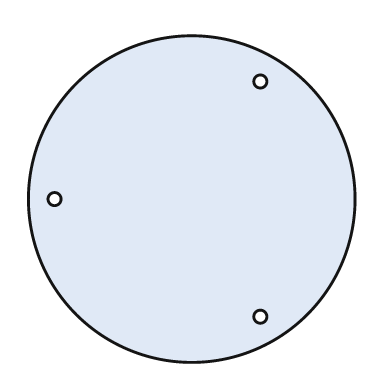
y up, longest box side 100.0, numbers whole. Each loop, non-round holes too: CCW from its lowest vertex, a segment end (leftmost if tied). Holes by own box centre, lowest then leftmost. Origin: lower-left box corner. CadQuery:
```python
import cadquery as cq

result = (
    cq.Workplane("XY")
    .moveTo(50.0, 50.0)
    .circle(50.0)
    .moveTo(71.0, 14.0)
    .circle(2.0)
    .moveTo(8.0, 50.0)
    .circle(2.0)
    .moveTo(71.0, 86.0)
    .circle(2.0)
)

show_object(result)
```